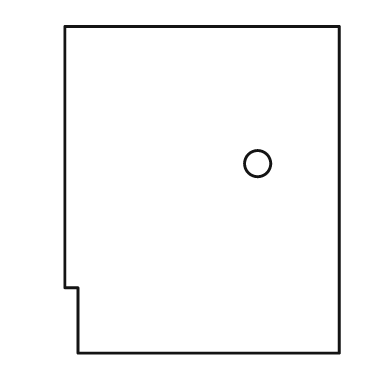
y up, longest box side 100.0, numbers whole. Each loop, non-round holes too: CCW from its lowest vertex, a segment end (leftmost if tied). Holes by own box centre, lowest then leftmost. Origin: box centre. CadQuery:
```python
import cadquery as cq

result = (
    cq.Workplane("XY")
    .moveTo(-38.0, -50.0)
    .lineTo(42.0, -50.0)
    .lineTo(42.0, 50.0)
    .lineTo(-42.0, 50.0)
    .lineTo(-42.0, -30.0)
    .lineTo(-38.0, -30.0)
    .close()
    .moveTo(17.0, 8.0)
    .circle(4.0)
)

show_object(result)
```